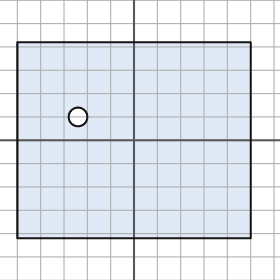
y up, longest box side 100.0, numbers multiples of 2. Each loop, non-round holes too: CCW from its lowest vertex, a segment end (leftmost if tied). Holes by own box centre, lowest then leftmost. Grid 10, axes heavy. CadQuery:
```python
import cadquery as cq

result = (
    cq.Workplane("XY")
    .moveTo(-50.0, -42.0)
    .lineTo(50.0, -42.0)
    .lineTo(50.0, 42.0)
    .lineTo(-50.0, 42.0)
    .close()
    .moveTo(-24.0, 10.0)
    .circle(4.0)
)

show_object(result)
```